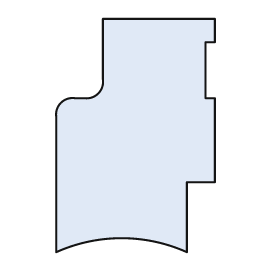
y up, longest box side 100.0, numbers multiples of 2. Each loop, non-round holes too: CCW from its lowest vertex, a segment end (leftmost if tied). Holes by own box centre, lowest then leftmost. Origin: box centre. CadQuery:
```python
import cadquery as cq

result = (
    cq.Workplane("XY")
    .moveTo(-34.0, -50.0)
    .threePointArc((-6.0, -44.0), (22.0, -50.0))
    .lineTo(22.0, -20.0)
    .lineTo(34.0, -20.0)
    .lineTo(34.0, 16.0)
    .lineTo(30.0, 16.0)
    .lineTo(30.0, 40.0)
    .lineTo(34.0, 40.0)
    .lineTo(34.0, 50.0)
    .lineTo(-14.0, 50.0)
    .lineTo(-14.0, 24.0)
    .threePointArc((-16.0, 18.0), (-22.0, 16.0))
    .lineTo(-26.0, 16.0)
    .threePointArc((-32.0, 14.0), (-34.0, 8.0))
    .close()
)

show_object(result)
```